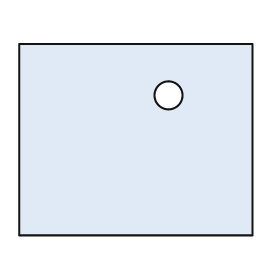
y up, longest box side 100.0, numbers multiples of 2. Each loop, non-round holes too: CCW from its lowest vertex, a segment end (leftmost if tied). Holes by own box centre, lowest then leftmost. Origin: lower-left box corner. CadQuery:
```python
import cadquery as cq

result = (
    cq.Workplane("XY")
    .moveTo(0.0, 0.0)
    .lineTo(100.0, 0.0)
    .lineTo(100.0, 82.0)
    .lineTo(0.0, 82.0)
    .close()
    .moveTo(64.0, 60.0)
    .circle(6.0)
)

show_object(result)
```